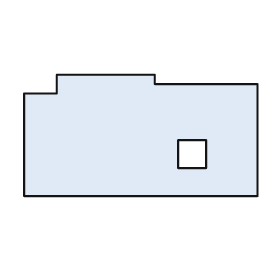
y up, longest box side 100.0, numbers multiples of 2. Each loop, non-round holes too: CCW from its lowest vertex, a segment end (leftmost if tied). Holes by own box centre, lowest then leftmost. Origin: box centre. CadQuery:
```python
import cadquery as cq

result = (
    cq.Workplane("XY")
    .moveTo(-50.0, -26.0)
    .lineTo(50.0, -26.0)
    .lineTo(50.0, 22.0)
    .lineTo(6.0, 22.0)
    .lineTo(6.0, 26.0)
    .lineTo(-36.0, 26.0)
    .lineTo(-36.0, 18.0)
    .lineTo(-50.0, 18.0)
    .close()
    .moveTo(16.0, -14.0)
    .lineTo(28.0, -14.0)
    .lineTo(28.0, -2.0)
    .lineTo(16.0, -2.0)
    .close()
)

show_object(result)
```